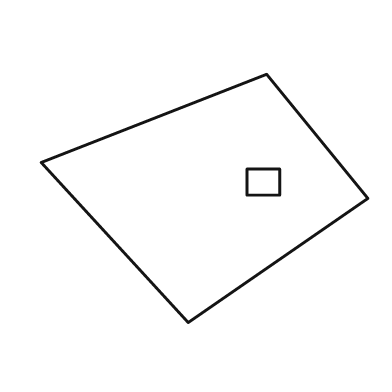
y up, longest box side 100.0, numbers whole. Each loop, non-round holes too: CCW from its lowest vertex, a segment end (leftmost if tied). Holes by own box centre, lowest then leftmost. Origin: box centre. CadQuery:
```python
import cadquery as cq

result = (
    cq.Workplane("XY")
    .moveTo(-5.0, -38.0)
    .lineTo(50.0, 0.0)
    .lineTo(19.0, 38.0)
    .lineTo(-50.0, 11.0)
    .close()
    .moveTo(13.0, 1.0)
    .lineTo(23.0, 1.0)
    .lineTo(23.0, 9.0)
    .lineTo(13.0, 9.0)
    .close()
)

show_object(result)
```